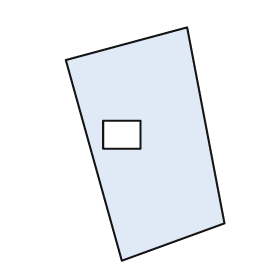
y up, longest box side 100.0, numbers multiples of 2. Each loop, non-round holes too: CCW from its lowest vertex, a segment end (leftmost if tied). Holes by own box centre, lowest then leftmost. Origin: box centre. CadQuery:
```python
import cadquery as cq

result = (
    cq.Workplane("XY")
    .moveTo(-10.0, -50.0)
    .lineTo(34.0, -34.0)
    .lineTo(18.0, 50.0)
    .lineTo(-34.0, 36.0)
    .close()
    .moveTo(-18.0, -2.0)
    .lineTo(-2.0, -2.0)
    .lineTo(-2.0, 10.0)
    .lineTo(-18.0, 10.0)
    .close()
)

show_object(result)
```